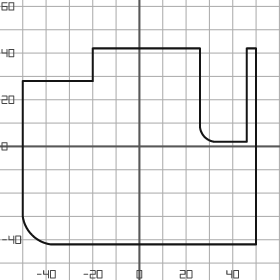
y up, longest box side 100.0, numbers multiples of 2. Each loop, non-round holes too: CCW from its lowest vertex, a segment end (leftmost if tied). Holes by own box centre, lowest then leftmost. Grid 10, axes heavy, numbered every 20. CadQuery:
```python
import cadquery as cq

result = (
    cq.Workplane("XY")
    .moveTo(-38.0, -42.0)
    .lineTo(50.0, -42.0)
    .lineTo(50.0, 42.0)
    .lineTo(46.0, 42.0)
    .lineTo(46.0, 2.0)
    .lineTo(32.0, 2.0)
    .threePointArc((28.0, 4.0), (26.0, 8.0))
    .lineTo(26.0, 42.0)
    .lineTo(-20.0, 42.0)
    .lineTo(-20.0, 28.0)
    .lineTo(-50.0, 28.0)
    .lineTo(-50.0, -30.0)
    .threePointArc((-46.0, -38.0), (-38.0, -42.0))
    .close()
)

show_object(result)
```